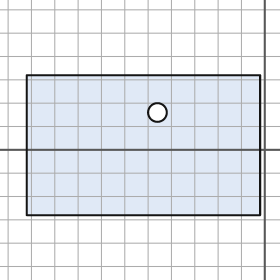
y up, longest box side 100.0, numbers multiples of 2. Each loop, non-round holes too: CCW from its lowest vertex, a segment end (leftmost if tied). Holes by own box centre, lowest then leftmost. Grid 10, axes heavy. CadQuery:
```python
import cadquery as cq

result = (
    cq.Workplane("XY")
    .moveTo(-102.0, -28.0)
    .lineTo(-2.0, -28.0)
    .lineTo(-2.0, 32.0)
    .lineTo(-102.0, 32.0)
    .close()
    .moveTo(-46.0, 16.0)
    .circle(4.0)
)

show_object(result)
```